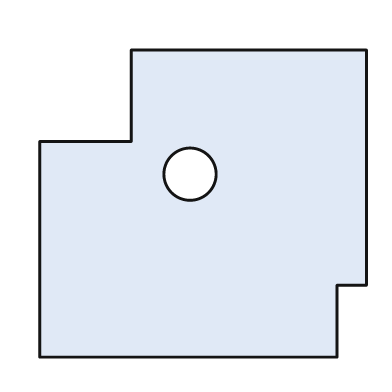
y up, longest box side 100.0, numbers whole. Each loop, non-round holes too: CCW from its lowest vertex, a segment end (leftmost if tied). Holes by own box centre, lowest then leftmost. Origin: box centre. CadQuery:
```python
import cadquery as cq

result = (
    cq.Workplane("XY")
    .moveTo(-50.0, -47.0)
    .lineTo(41.0, -47.0)
    .lineTo(41.0, -25.0)
    .lineTo(50.0, -25.0)
    .lineTo(50.0, 47.0)
    .lineTo(-22.0, 47.0)
    .lineTo(-22.0, 19.0)
    .lineTo(-50.0, 19.0)
    .close()
    .moveTo(-4.0, 9.0)
    .circle(8.0)
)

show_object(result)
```